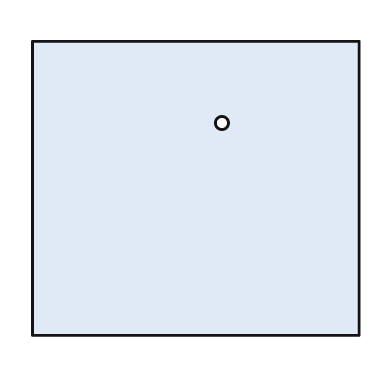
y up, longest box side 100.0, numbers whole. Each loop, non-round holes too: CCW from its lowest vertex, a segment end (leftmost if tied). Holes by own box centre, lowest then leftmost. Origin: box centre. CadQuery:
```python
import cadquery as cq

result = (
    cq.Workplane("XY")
    .moveTo(-50.0, -45.0)
    .lineTo(50.0, -45.0)
    .lineTo(50.0, 45.0)
    .lineTo(-50.0, 45.0)
    .close()
    .moveTo(8.0, 20.0)
    .circle(2.0)
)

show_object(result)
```